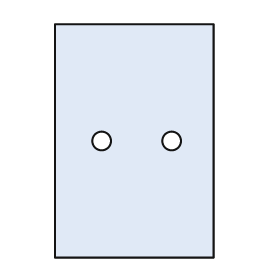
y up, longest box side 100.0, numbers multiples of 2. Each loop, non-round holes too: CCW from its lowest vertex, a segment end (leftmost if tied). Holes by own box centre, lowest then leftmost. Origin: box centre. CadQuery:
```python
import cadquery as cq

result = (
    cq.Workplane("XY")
    .moveTo(-34.0, -50.0)
    .lineTo(34.0, -50.0)
    .lineTo(34.0, 50.0)
    .lineTo(-34.0, 50.0)
    .close()
    .moveTo(-14.0, 0.0)
    .circle(4.0)
    .moveTo(16.0, 0.0)
    .circle(4.0)
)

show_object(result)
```